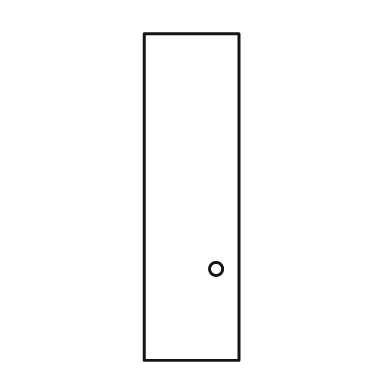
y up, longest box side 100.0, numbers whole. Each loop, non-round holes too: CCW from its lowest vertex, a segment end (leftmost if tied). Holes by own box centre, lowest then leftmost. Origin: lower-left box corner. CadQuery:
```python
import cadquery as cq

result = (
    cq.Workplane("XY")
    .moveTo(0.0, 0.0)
    .lineTo(29.0, 0.0)
    .lineTo(29.0, 100.0)
    .lineTo(0.0, 100.0)
    .close()
    .moveTo(22.0, 28.0)
    .circle(2.0)
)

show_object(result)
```